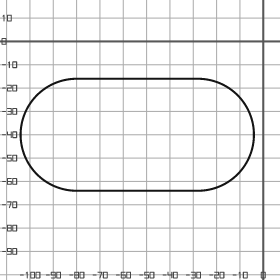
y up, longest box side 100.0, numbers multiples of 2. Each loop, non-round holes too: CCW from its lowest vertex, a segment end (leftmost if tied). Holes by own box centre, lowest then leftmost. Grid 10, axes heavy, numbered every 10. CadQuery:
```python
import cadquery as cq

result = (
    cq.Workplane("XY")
    .moveTo(-80.0, -64.0)
    .lineTo(-28.0, -64.0)
    .threePointArc((-4.0, -40.0), (-28.0, -16.0))
    .lineTo(-80.0, -16.0)
    .threePointArc((-104.0, -40.0), (-80.0, -64.0))
    .close()
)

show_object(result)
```